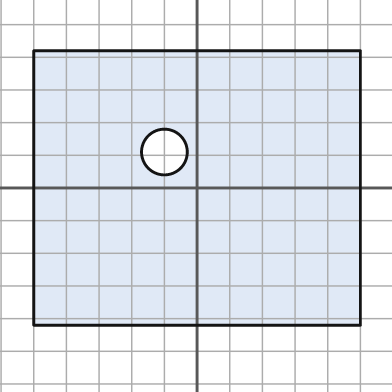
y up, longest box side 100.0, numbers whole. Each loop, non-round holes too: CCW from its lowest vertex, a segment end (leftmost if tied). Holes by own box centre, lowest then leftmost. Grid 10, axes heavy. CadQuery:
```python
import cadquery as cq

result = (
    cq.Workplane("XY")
    .moveTo(-50.0, -42.0)
    .lineTo(50.0, -42.0)
    .lineTo(50.0, 42.0)
    .lineTo(-50.0, 42.0)
    .close()
    .moveTo(-10.0, 11.0)
    .circle(7.0)
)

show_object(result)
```